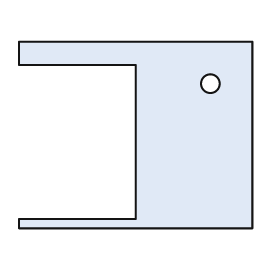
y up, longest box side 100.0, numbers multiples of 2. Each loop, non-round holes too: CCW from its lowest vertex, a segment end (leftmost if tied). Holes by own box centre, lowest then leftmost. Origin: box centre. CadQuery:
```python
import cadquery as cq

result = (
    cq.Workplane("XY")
    .moveTo(-50.0, -40.0)
    .lineTo(50.0, -40.0)
    .lineTo(50.0, 40.0)
    .lineTo(-50.0, 40.0)
    .lineTo(-50.0, 30.0)
    .lineTo(0.0, 30.0)
    .lineTo(0.0, -36.0)
    .lineTo(-50.0, -36.0)
    .close()
    .moveTo(32.0, 22.0)
    .circle(4.0)
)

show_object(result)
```